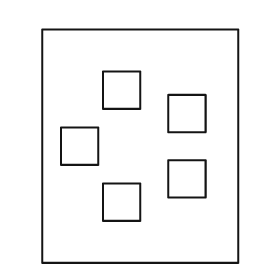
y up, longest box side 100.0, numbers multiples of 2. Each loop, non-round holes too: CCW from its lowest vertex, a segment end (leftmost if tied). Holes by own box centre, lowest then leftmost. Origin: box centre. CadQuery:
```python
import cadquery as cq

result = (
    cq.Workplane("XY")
    .moveTo(-42.0, -50.0)
    .lineTo(42.0, -50.0)
    .lineTo(42.0, 50.0)
    .lineTo(-42.0, 50.0)
    .close()
    .moveTo(-16.0, -32.0)
    .lineTo(0.0, -32.0)
    .lineTo(0.0, -16.0)
    .lineTo(-16.0, -16.0)
    .close()
    .moveTo(12.0, -22.0)
    .lineTo(28.0, -22.0)
    .lineTo(28.0, -6.0)
    .lineTo(12.0, -6.0)
    .close()
    .moveTo(-34.0, -8.0)
    .lineTo(-18.0, -8.0)
    .lineTo(-18.0, 8.0)
    .lineTo(-34.0, 8.0)
    .close()
    .moveTo(12.0, 6.0)
    .lineTo(28.0, 6.0)
    .lineTo(28.0, 22.0)
    .lineTo(12.0, 22.0)
    .close()
    .moveTo(-16.0, 16.0)
    .lineTo(0.0, 16.0)
    .lineTo(0.0, 32.0)
    .lineTo(-16.0, 32.0)
    .close()
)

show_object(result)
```